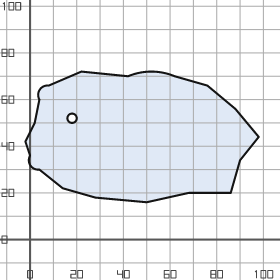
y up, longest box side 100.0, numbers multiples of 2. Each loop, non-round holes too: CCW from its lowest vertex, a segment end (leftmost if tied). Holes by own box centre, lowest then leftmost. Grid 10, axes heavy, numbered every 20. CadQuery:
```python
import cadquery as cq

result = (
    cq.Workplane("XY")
    .moveTo(50.0, 16.0)
    .lineTo(68.0, 20.0)
    .lineTo(86.0, 20.0)
    .lineTo(90.0, 34.0)
    .lineTo(98.0, 44.0)
    .lineTo(88.0, 56.0)
    .lineTo(76.0, 66.0)
    .lineTo(62.0, 70.0)
    .threePointArc((52.0, 72.0), (42.0, 70.0))
    .lineTo(22.0, 72.0)
    .lineTo(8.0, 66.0)
    .threePointArc((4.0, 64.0), (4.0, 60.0))
    .lineTo(2.0, 50.0)
    .lineTo(-2.0, 42.0)
    .lineTo(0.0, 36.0)
    .threePointArc((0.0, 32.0), (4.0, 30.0))
    .lineTo(14.0, 22.0)
    .lineTo(28.0, 18.0)
    .close()
    .moveTo(18.0, 52.0)
    .circle(2.0)
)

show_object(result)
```